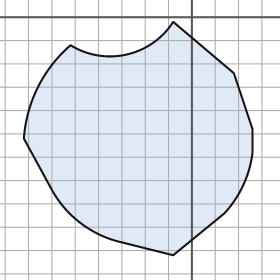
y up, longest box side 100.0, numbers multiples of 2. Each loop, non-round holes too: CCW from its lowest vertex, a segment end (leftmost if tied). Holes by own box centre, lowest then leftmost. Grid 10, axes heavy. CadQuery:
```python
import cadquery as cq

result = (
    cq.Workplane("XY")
    .moveTo(-8.0, -102.0)
    .lineTo(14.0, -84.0)
    .threePointArc((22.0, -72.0), (26.0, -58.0))
    .lineTo(26.0, -48.0)
    .lineTo(18.0, -24.0)
    .lineTo(-8.0, -2.0)
    .threePointArc((-28.0, -16.0), (-52.0, -12.0))
    .threePointArc((-66.0, -30.0), (-72.0, -52.0))
    .lineTo(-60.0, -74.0)
    .threePointArc((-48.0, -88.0), (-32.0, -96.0))
    .close()
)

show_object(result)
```